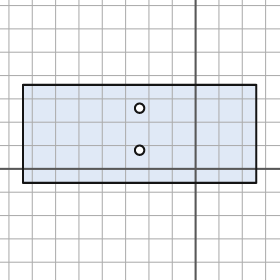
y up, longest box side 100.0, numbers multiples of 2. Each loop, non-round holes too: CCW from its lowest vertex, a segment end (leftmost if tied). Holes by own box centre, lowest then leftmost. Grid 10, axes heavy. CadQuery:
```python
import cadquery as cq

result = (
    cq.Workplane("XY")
    .moveTo(-74.0, -6.0)
    .lineTo(26.0, -6.0)
    .lineTo(26.0, 36.0)
    .lineTo(-74.0, 36.0)
    .close()
    .moveTo(-24.0, 8.0)
    .circle(2.0)
    .moveTo(-24.0, 26.0)
    .circle(2.0)
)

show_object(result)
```